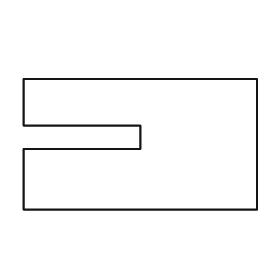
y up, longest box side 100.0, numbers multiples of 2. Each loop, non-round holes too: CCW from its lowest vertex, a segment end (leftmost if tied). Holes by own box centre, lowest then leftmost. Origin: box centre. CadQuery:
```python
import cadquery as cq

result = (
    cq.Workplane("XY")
    .moveTo(-50.0, -28.0)
    .lineTo(50.0, -28.0)
    .lineTo(50.0, 28.0)
    .lineTo(-50.0, 28.0)
    .lineTo(-50.0, 8.0)
    .lineTo(0.0, 8.0)
    .lineTo(0.0, -2.0)
    .lineTo(-50.0, -2.0)
    .close()
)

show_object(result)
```